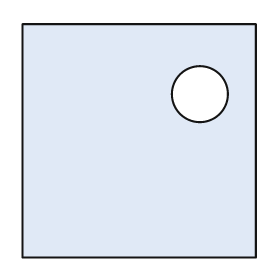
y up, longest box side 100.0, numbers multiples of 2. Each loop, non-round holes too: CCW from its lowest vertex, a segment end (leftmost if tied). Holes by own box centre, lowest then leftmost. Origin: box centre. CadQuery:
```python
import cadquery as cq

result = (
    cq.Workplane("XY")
    .moveTo(-50.0, -50.0)
    .lineTo(50.0, -50.0)
    .lineTo(50.0, 50.0)
    .lineTo(-50.0, 50.0)
    .close()
    .moveTo(26.0, 20.0)
    .circle(12.0)
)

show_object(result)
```